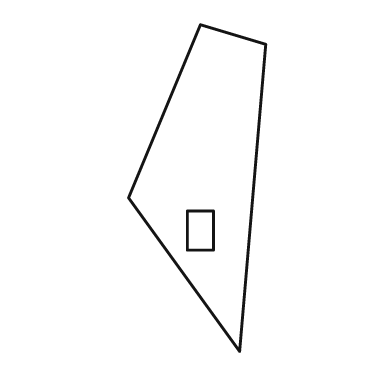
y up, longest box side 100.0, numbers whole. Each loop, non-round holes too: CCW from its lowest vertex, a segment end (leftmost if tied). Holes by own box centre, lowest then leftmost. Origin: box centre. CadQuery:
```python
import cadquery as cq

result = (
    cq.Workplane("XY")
    .moveTo(13.0, -50.0)
    .lineTo(21.0, 44.0)
    .lineTo(1.0, 50.0)
    .lineTo(-21.0, -3.0)
    .close()
    .moveTo(-3.0, -19.0)
    .lineTo(5.0, -19.0)
    .lineTo(5.0, -7.0)
    .lineTo(-3.0, -7.0)
    .close()
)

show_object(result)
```